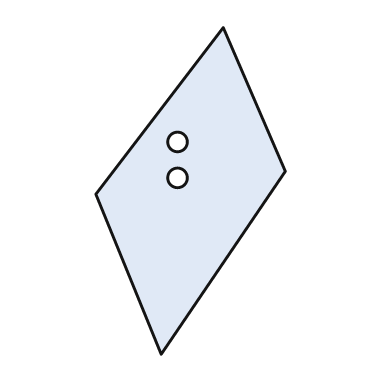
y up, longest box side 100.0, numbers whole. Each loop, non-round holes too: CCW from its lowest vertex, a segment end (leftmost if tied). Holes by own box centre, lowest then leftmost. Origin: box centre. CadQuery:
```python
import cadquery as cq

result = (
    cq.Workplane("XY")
    .moveTo(-9.0, -50.0)
    .lineTo(29.0, 6.0)
    .lineTo(10.0, 50.0)
    .lineTo(-29.0, -1.0)
    .close()
    .moveTo(-4.0, 4.0)
    .circle(3.0)
    .moveTo(-4.0, 15.0)
    .circle(3.0)
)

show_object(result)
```